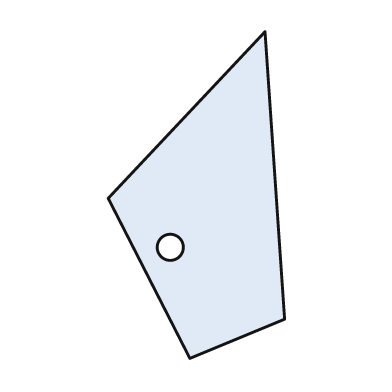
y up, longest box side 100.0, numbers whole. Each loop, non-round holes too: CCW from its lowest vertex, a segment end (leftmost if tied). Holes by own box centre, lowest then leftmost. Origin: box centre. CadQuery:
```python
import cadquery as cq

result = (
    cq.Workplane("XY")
    .moveTo(-2.0, -50.0)
    .lineTo(27.0, -38.0)
    .lineTo(21.0, 50.0)
    .lineTo(-27.0, -1.0)
    .close()
    .moveTo(-8.0, -16.0)
    .circle(4.0)
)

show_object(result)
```